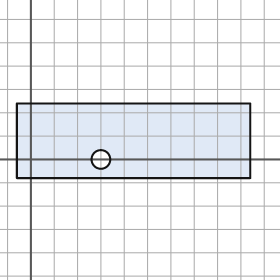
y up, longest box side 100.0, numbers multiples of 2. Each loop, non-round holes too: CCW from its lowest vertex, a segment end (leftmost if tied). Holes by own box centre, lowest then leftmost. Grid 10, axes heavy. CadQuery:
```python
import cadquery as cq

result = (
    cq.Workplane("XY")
    .moveTo(-6.0, -8.0)
    .lineTo(94.0, -8.0)
    .lineTo(94.0, 24.0)
    .lineTo(-6.0, 24.0)
    .close()
    .moveTo(30.0, 0.0)
    .circle(4.0)
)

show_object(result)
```